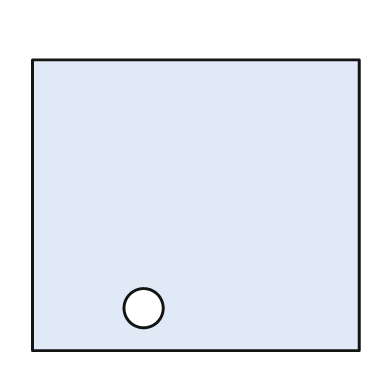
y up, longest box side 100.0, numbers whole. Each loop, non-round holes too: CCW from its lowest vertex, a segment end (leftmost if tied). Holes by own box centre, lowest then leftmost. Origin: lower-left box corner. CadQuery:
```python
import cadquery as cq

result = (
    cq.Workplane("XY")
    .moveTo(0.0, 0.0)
    .lineTo(100.0, 0.0)
    .lineTo(100.0, 89.0)
    .lineTo(0.0, 89.0)
    .close()
    .moveTo(34.0, 13.0)
    .circle(6.0)
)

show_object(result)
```